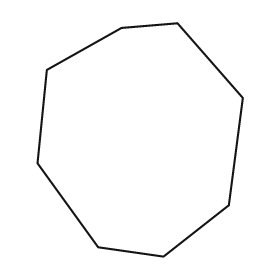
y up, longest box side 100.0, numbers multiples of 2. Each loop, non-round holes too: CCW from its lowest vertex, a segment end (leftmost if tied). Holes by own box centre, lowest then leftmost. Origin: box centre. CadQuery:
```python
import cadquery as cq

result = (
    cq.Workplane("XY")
    .moveTo(10.0, -50.0)
    .lineTo(38.0, -28.0)
    .lineTo(44.0, 18.0)
    .lineTo(16.0, 50.0)
    .lineTo(-8.0, 48.0)
    .lineTo(-40.0, 30.0)
    .lineTo(-44.0, -10.0)
    .lineTo(-18.0, -46.0)
    .close()
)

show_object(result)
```